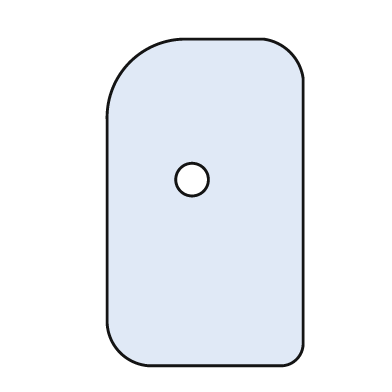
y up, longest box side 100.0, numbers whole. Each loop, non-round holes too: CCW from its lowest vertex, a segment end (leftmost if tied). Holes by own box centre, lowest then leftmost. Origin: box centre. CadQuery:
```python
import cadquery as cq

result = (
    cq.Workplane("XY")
    .moveTo(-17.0, -50.0)
    .lineTo(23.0, -50.0)
    .threePointArc((28.0, -48.0), (30.0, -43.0))
    .lineTo(30.0, 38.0)
    .threePointArc((26.0, 46.0), (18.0, 50.0))
    .lineTo(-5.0, 50.0)
    .threePointArc((-23.0, 43.0), (-30.0, 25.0))
    .lineTo(-30.0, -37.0)
    .threePointArc((-26.0, -46.0), (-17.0, -50.0))
    .close()
    .moveTo(-4.0, 7.0)
    .circle(5.0)
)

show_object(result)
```